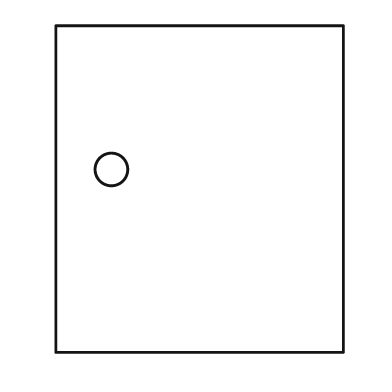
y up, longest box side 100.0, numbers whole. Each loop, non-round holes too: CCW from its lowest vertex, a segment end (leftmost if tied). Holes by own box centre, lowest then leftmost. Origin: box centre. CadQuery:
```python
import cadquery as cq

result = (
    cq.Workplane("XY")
    .moveTo(-44.0, -50.0)
    .lineTo(44.0, -50.0)
    .lineTo(44.0, 50.0)
    .lineTo(-44.0, 50.0)
    .close()
    .moveTo(-27.0, 6.0)
    .circle(5.0)
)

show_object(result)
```